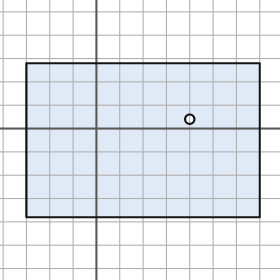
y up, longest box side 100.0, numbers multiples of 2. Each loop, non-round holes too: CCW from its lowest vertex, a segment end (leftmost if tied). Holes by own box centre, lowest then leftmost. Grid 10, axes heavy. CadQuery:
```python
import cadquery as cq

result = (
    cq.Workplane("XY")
    .moveTo(-30.0, -38.0)
    .lineTo(70.0, -38.0)
    .lineTo(70.0, 28.0)
    .lineTo(-30.0, 28.0)
    .close()
    .moveTo(40.0, 4.0)
    .circle(2.0)
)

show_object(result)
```